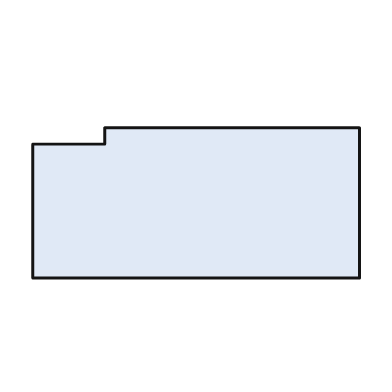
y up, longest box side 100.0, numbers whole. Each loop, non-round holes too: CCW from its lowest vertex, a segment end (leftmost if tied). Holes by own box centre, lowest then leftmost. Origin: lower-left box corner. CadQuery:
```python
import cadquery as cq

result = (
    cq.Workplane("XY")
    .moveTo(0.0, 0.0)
    .lineTo(100.0, 0.0)
    .lineTo(100.0, 46.0)
    .lineTo(22.0, 46.0)
    .lineTo(22.0, 41.0)
    .lineTo(0.0, 41.0)
    .close()
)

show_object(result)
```